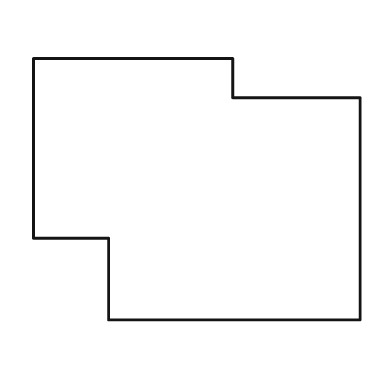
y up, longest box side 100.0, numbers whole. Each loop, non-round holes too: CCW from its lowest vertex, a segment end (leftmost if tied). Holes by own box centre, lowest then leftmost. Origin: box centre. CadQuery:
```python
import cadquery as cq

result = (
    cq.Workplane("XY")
    .moveTo(-27.0, -40.0)
    .lineTo(50.0, -40.0)
    .lineTo(50.0, 28.0)
    .lineTo(11.0, 28.0)
    .lineTo(11.0, 40.0)
    .lineTo(-50.0, 40.0)
    .lineTo(-50.0, -15.0)
    .lineTo(-27.0, -15.0)
    .close()
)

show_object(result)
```